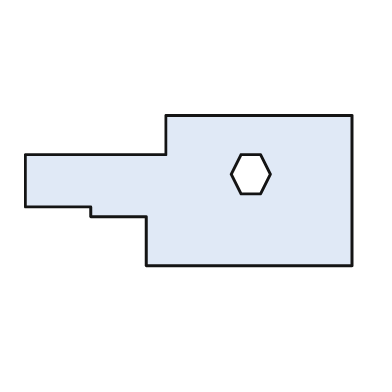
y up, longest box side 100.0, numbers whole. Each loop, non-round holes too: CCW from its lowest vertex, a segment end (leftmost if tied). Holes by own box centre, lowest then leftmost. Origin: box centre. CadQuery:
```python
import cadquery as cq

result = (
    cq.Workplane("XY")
    .moveTo(-13.0, -23.0)
    .lineTo(50.0, -23.0)
    .lineTo(50.0, 23.0)
    .lineTo(-7.0, 23.0)
    .lineTo(-7.0, 11.0)
    .lineTo(-50.0, 11.0)
    .lineTo(-50.0, -5.0)
    .lineTo(-30.0, -5.0)
    .lineTo(-30.0, -8.0)
    .lineTo(-13.0, -8.0)
    .close()
    .moveTo(16.0, -1.0)
    .lineTo(22.0, -1.0)
    .lineTo(25.0, 5.0)
    .lineTo(22.0, 11.0)
    .lineTo(16.0, 11.0)
    .lineTo(13.0, 5.0)
    .close()
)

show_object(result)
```